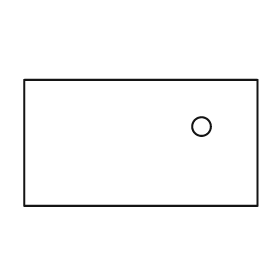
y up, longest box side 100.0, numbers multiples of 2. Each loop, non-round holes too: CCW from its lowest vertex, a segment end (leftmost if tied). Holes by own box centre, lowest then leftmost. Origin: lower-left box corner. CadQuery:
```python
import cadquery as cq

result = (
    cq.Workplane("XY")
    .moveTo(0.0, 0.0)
    .lineTo(100.0, 0.0)
    .lineTo(100.0, 54.0)
    .lineTo(0.0, 54.0)
    .close()
    .moveTo(76.0, 34.0)
    .circle(4.0)
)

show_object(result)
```